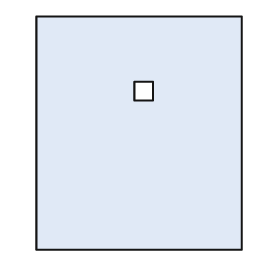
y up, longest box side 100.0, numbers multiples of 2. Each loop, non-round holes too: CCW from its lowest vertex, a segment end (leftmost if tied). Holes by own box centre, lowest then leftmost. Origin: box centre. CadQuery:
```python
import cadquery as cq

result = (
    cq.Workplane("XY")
    .moveTo(-44.0, -50.0)
    .lineTo(44.0, -50.0)
    .lineTo(44.0, 50.0)
    .lineTo(-44.0, 50.0)
    .close()
    .moveTo(-2.0, 14.0)
    .lineTo(6.0, 14.0)
    .lineTo(6.0, 22.0)
    .lineTo(-2.0, 22.0)
    .close()
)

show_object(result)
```